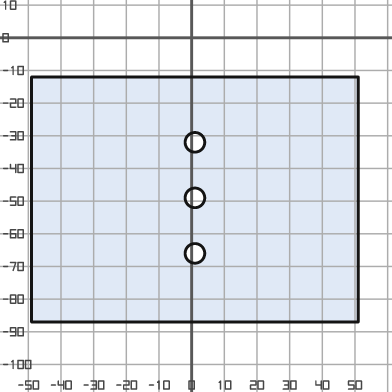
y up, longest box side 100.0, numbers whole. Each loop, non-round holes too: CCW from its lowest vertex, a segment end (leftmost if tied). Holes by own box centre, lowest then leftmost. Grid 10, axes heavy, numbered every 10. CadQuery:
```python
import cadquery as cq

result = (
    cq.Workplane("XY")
    .moveTo(-49.0, -87.0)
    .lineTo(51.0, -87.0)
    .lineTo(51.0, -12.0)
    .lineTo(-49.0, -12.0)
    .close()
    .moveTo(1.0, -66.0)
    .circle(3.0)
    .moveTo(1.0, -49.0)
    .circle(3.0)
    .moveTo(1.0, -32.0)
    .circle(3.0)
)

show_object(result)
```